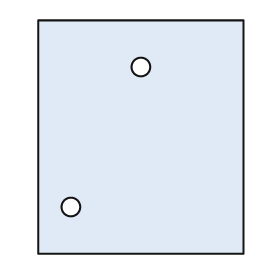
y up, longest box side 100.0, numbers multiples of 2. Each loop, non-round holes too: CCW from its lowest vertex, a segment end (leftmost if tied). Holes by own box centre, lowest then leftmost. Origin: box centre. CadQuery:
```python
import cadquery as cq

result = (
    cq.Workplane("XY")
    .moveTo(-44.0, -50.0)
    .lineTo(44.0, -50.0)
    .lineTo(44.0, 50.0)
    .lineTo(-44.0, 50.0)
    .close()
    .moveTo(-30.0, -30.0)
    .circle(4.0)
    .moveTo(0.0, 30.0)
    .circle(4.0)
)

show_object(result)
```